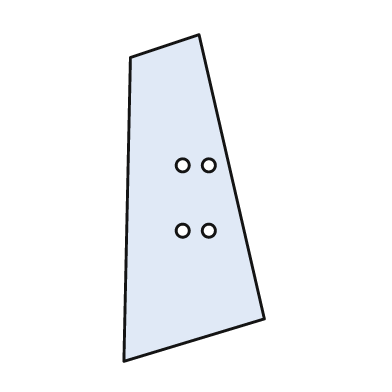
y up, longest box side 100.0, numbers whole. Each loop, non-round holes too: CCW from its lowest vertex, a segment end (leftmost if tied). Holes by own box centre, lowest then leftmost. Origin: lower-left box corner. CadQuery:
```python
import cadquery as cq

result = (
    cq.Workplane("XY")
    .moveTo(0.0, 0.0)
    .lineTo(43.0, 13.0)
    .lineTo(23.0, 100.0)
    .lineTo(2.0, 93.0)
    .close()
    .moveTo(18.0, 40.0)
    .circle(2.0)
    .moveTo(26.0, 40.0)
    .circle(2.0)
    .moveTo(18.0, 60.0)
    .circle(2.0)
    .moveTo(26.0, 60.0)
    .circle(2.0)
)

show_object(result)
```